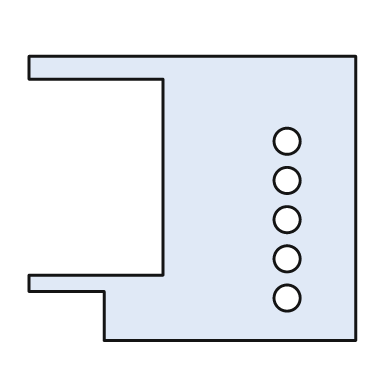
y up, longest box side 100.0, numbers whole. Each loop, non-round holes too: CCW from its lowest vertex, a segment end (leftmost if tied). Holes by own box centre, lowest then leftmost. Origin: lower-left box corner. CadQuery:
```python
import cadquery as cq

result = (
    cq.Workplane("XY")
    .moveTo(23.0, 0.0)
    .lineTo(100.0, 0.0)
    .lineTo(100.0, 87.0)
    .lineTo(0.0, 87.0)
    .lineTo(0.0, 80.0)
    .lineTo(41.0, 80.0)
    .lineTo(41.0, 20.0)
    .lineTo(0.0, 20.0)
    .lineTo(0.0, 15.0)
    .lineTo(23.0, 15.0)
    .close()
    .moveTo(79.0, 13.0)
    .circle(4.0)
    .moveTo(79.0, 25.0)
    .circle(4.0)
    .moveTo(79.0, 37.0)
    .circle(4.0)
    .moveTo(79.0, 49.0)
    .circle(4.0)
    .moveTo(79.0, 61.0)
    .circle(4.0)
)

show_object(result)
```